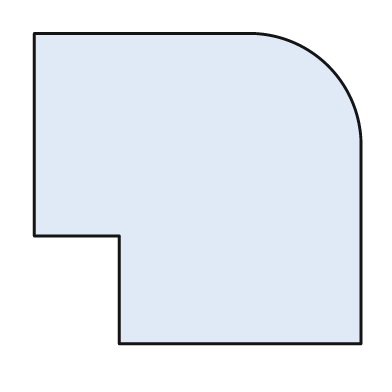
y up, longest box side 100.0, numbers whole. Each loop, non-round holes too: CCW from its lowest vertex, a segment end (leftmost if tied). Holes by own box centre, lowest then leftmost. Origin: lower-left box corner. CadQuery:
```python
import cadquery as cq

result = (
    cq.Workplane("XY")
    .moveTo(26.0, 0.0)
    .lineTo(100.0, 0.0)
    .lineTo(100.0, 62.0)
    .threePointArc((90.0, 85.0), (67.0, 95.0))
    .lineTo(0.0, 95.0)
    .lineTo(0.0, 33.0)
    .lineTo(26.0, 33.0)
    .close()
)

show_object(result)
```